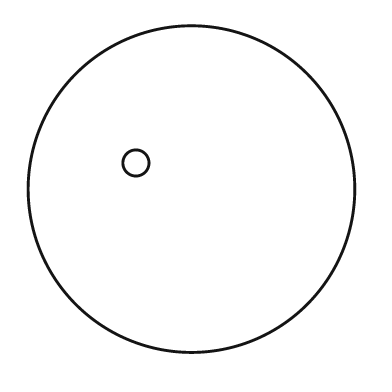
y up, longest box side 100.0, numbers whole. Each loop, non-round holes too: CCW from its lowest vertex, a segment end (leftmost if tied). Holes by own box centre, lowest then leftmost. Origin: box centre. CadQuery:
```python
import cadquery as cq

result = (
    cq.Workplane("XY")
    .moveTo(0.0, 0.0)
    .circle(50.0)
    .moveTo(-17.0, 8.0)
    .circle(4.0)
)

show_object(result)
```